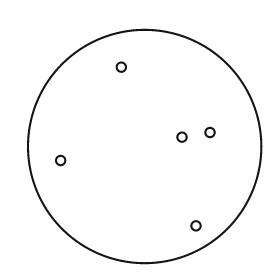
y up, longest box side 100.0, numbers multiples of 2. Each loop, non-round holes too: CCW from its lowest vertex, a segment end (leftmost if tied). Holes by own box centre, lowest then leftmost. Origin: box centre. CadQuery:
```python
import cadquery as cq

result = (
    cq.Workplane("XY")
    .moveTo(0.0, 0.0)
    .circle(50.0)
    .moveTo(22.0, -34.0)
    .circle(2.0)
    .moveTo(-36.0, -6.0)
    .circle(2.0)
    .moveTo(16.0, 4.0)
    .circle(2.0)
    .moveTo(28.0, 6.0)
    .circle(2.0)
    .moveTo(-10.0, 34.0)
    .circle(2.0)
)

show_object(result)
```